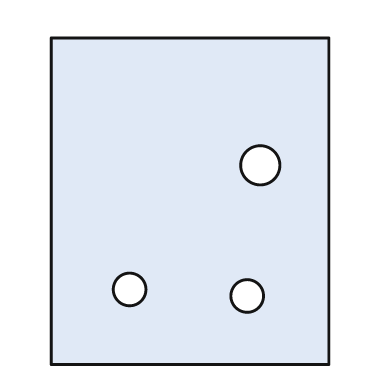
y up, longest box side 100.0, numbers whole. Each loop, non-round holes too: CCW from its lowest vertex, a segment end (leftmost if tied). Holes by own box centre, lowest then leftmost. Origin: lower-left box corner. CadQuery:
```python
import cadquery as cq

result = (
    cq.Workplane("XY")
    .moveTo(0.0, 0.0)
    .lineTo(85.0, 0.0)
    .lineTo(85.0, 100.0)
    .lineTo(0.0, 100.0)
    .close()
    .moveTo(60.0, 21.0)
    .circle(5.0)
    .moveTo(24.0, 23.0)
    .circle(5.0)
    .moveTo(64.0, 61.0)
    .circle(6.0)
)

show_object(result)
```